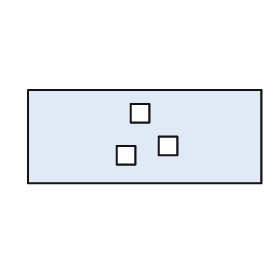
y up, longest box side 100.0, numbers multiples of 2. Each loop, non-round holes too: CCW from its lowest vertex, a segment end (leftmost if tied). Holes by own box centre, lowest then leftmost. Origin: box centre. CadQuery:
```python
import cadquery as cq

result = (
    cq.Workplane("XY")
    .moveTo(-50.0, -20.0)
    .lineTo(50.0, -20.0)
    .lineTo(50.0, 20.0)
    .lineTo(-50.0, 20.0)
    .close()
    .moveTo(-12.0, -12.0)
    .lineTo(-4.0, -12.0)
    .lineTo(-4.0, -4.0)
    .lineTo(-12.0, -4.0)
    .close()
    .moveTo(6.0, -8.0)
    .lineTo(14.0, -8.0)
    .lineTo(14.0, 0.0)
    .lineTo(6.0, 0.0)
    .close()
    .moveTo(-6.0, 6.0)
    .lineTo(2.0, 6.0)
    .lineTo(2.0, 14.0)
    .lineTo(-6.0, 14.0)
    .close()
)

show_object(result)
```